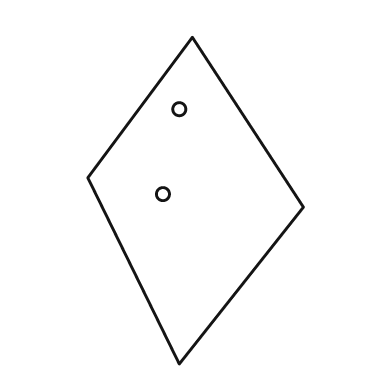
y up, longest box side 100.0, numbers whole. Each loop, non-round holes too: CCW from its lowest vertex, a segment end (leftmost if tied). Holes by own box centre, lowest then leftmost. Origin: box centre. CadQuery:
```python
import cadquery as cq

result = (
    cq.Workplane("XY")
    .moveTo(-5.0, -50.0)
    .lineTo(33.0, -2.0)
    .lineTo(-1.0, 50.0)
    .lineTo(-33.0, 7.0)
    .close()
    .moveTo(-10.0, 2.0)
    .circle(2.0)
    .moveTo(-5.0, 28.0)
    .circle(2.0)
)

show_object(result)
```